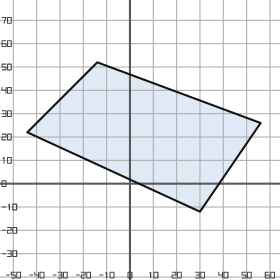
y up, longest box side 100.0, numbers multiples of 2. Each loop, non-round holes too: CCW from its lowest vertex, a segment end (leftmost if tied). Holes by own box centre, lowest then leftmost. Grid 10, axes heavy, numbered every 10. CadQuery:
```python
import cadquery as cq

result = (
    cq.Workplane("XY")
    .moveTo(30.0, -12.0)
    .lineTo(56.0, 26.0)
    .lineTo(-14.0, 52.0)
    .lineTo(-44.0, 22.0)
    .close()
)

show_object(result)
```